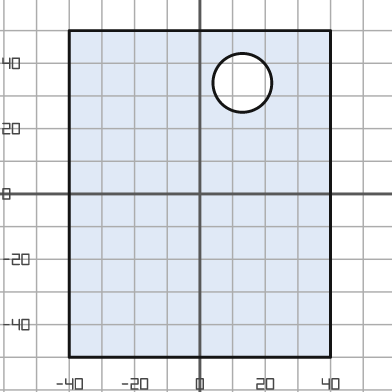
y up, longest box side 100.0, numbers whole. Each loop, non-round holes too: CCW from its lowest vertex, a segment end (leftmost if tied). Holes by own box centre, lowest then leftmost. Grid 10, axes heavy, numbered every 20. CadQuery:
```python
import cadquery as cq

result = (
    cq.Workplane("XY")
    .moveTo(-40.0, -50.0)
    .lineTo(40.0, -50.0)
    .lineTo(40.0, 50.0)
    .lineTo(-40.0, 50.0)
    .close()
    .moveTo(13.0, 34.0)
    .circle(9.0)
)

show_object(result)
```